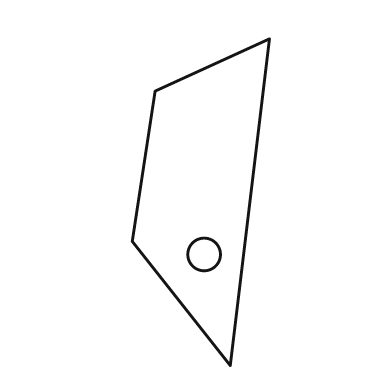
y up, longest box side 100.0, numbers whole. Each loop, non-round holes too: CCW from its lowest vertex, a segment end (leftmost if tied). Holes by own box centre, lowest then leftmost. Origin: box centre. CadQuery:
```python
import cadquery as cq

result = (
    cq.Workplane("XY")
    .moveTo(9.0, -50.0)
    .lineTo(21.0, 50.0)
    .lineTo(-14.0, 34.0)
    .lineTo(-21.0, -12.0)
    .close()
    .moveTo(1.0, -16.0)
    .circle(5.0)
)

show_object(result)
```